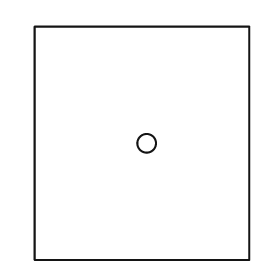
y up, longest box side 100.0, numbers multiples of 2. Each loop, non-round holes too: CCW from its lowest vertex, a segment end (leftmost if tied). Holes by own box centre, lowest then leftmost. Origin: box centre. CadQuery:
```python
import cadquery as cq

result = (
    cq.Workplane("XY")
    .moveTo(-46.0, -50.0)
    .lineTo(46.0, -50.0)
    .lineTo(46.0, 50.0)
    .lineTo(-46.0, 50.0)
    .close()
    .moveTo(2.0, 0.0)
    .circle(4.0)
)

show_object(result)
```